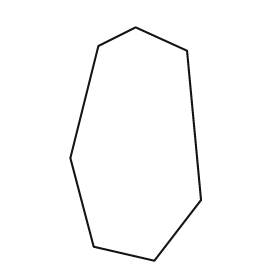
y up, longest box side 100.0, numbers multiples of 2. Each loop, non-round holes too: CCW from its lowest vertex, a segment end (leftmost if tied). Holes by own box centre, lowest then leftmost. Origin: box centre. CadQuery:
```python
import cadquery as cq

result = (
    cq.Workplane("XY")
    .moveTo(8.0, -50.0)
    .lineTo(28.0, -24.0)
    .lineTo(22.0, 40.0)
    .lineTo(0.0, 50.0)
    .lineTo(-16.0, 42.0)
    .lineTo(-28.0, -6.0)
    .lineTo(-18.0, -44.0)
    .close()
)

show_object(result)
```